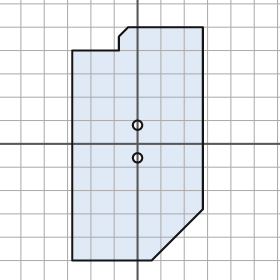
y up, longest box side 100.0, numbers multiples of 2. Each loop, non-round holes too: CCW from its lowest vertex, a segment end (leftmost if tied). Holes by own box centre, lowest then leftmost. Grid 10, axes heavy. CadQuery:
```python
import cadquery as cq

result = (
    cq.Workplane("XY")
    .moveTo(-28.0, -50.0)
    .lineTo(6.0, -50.0)
    .lineTo(28.0, -28.0)
    .lineTo(28.0, 50.0)
    .lineTo(-4.0, 50.0)
    .lineTo(-8.0, 46.0)
    .lineTo(-8.0, 40.0)
    .lineTo(-28.0, 40.0)
    .close()
    .moveTo(0.0, -6.0)
    .circle(2.0)
    .moveTo(0.0, 8.0)
    .circle(2.0)
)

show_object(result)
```